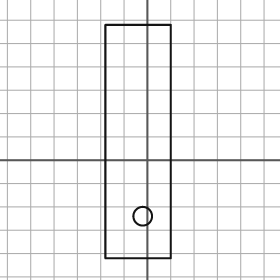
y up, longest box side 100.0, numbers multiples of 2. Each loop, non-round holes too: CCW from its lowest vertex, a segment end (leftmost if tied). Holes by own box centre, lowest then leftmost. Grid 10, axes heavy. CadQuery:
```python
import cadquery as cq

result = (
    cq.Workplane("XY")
    .moveTo(-18.0, -42.0)
    .lineTo(10.0, -42.0)
    .lineTo(10.0, 58.0)
    .lineTo(-18.0, 58.0)
    .close()
    .moveTo(-2.0, -24.0)
    .circle(4.0)
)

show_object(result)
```